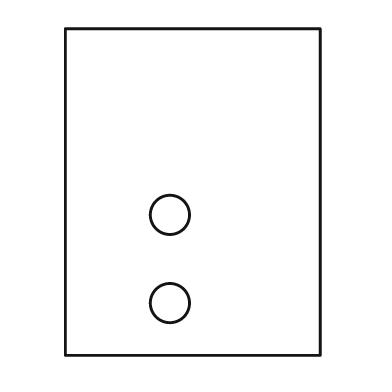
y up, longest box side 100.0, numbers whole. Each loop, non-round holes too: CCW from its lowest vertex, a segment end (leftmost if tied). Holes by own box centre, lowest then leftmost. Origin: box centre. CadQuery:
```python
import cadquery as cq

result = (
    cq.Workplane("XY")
    .moveTo(-39.0, -50.0)
    .lineTo(39.0, -50.0)
    .lineTo(39.0, 50.0)
    .lineTo(-39.0, 50.0)
    .close()
    .moveTo(-7.0, -34.0)
    .circle(6.0)
    .moveTo(-7.0, -7.0)
    .circle(6.0)
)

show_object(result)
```